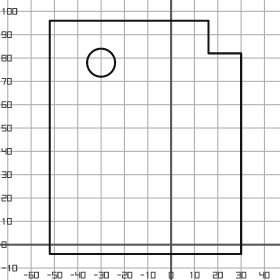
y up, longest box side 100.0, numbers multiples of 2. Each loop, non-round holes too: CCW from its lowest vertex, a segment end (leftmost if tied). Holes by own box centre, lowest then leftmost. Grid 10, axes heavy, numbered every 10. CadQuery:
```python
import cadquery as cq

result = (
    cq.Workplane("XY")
    .moveTo(-52.0, -4.0)
    .lineTo(30.0, -4.0)
    .lineTo(30.0, 82.0)
    .lineTo(16.0, 82.0)
    .lineTo(16.0, 96.0)
    .lineTo(-52.0, 96.0)
    .close()
    .moveTo(-30.0, 78.0)
    .circle(6.0)
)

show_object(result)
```